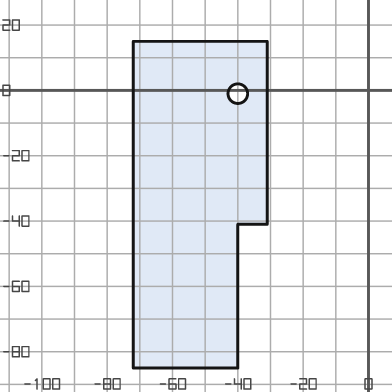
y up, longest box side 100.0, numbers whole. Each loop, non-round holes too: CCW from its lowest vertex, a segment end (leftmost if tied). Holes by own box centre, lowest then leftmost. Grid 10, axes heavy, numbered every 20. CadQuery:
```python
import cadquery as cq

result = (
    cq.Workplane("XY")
    .moveTo(-72.0, -85.0)
    .lineTo(-40.0, -85.0)
    .lineTo(-40.0, -41.0)
    .lineTo(-31.0, -41.0)
    .lineTo(-31.0, 15.0)
    .lineTo(-72.0, 15.0)
    .close()
    .moveTo(-40.0, -1.0)
    .circle(3.0)
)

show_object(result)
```